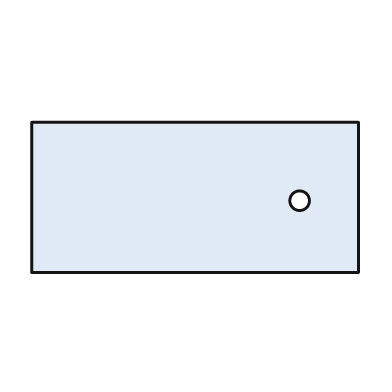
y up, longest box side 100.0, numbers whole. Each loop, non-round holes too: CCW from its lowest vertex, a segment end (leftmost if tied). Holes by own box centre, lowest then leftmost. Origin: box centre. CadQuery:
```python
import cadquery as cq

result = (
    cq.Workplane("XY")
    .moveTo(-50.0, -23.0)
    .lineTo(50.0, -23.0)
    .lineTo(50.0, 23.0)
    .lineTo(-50.0, 23.0)
    .close()
    .moveTo(32.0, -1.0)
    .circle(3.0)
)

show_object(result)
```